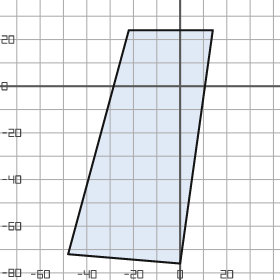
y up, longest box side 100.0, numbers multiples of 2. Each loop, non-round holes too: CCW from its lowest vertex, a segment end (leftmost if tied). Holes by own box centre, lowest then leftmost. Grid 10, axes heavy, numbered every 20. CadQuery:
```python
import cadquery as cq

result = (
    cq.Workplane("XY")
    .moveTo(0.0, -76.0)
    .lineTo(14.0, 24.0)
    .lineTo(-22.0, 24.0)
    .lineTo(-48.0, -72.0)
    .close()
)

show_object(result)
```